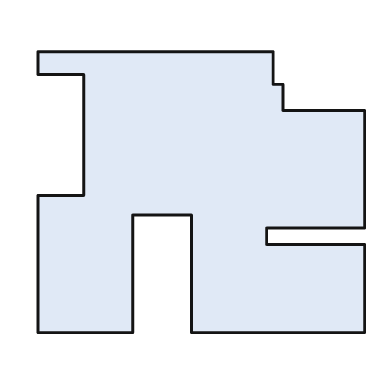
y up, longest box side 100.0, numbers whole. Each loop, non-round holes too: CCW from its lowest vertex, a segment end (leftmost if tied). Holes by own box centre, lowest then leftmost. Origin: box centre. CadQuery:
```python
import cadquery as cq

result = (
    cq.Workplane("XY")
    .moveTo(-50.0, -43.0)
    .lineTo(-21.0, -43.0)
    .lineTo(-21.0, -7.0)
    .lineTo(-3.0, -7.0)
    .lineTo(-3.0, -43.0)
    .lineTo(50.0, -43.0)
    .lineTo(50.0, -16.0)
    .lineTo(20.0, -16.0)
    .lineTo(20.0, -11.0)
    .lineTo(50.0, -11.0)
    .lineTo(50.0, 25.0)
    .lineTo(25.0, 25.0)
    .lineTo(25.0, 33.0)
    .lineTo(22.0, 33.0)
    .lineTo(22.0, 43.0)
    .lineTo(-50.0, 43.0)
    .lineTo(-50.0, 36.0)
    .lineTo(-36.0, 36.0)
    .lineTo(-36.0, -1.0)
    .lineTo(-50.0, -1.0)
    .close()
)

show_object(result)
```